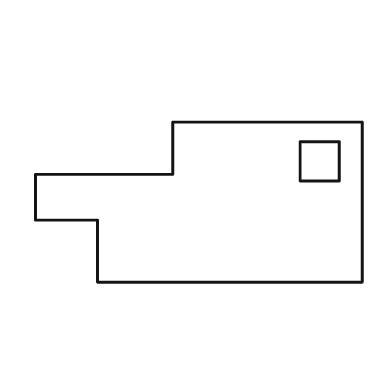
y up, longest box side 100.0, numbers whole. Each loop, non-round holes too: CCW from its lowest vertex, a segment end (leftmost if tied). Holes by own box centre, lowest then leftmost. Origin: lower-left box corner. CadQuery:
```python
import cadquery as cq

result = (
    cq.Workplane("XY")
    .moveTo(19.0, 0.0)
    .lineTo(100.0, 0.0)
    .lineTo(100.0, 49.0)
    .lineTo(42.0, 49.0)
    .lineTo(42.0, 33.0)
    .lineTo(0.0, 33.0)
    .lineTo(0.0, 19.0)
    .lineTo(19.0, 19.0)
    .close()
    .moveTo(81.0, 31.0)
    .lineTo(93.0, 31.0)
    .lineTo(93.0, 43.0)
    .lineTo(81.0, 43.0)
    .close()
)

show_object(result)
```